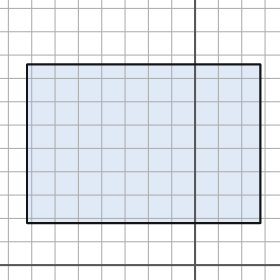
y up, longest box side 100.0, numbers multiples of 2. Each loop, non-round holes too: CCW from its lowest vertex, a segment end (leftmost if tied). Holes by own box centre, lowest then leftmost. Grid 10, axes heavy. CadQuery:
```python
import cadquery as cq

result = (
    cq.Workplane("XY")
    .moveTo(-72.0, 18.0)
    .lineTo(28.0, 18.0)
    .lineTo(28.0, 86.0)
    .lineTo(-72.0, 86.0)
    .close()
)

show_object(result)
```